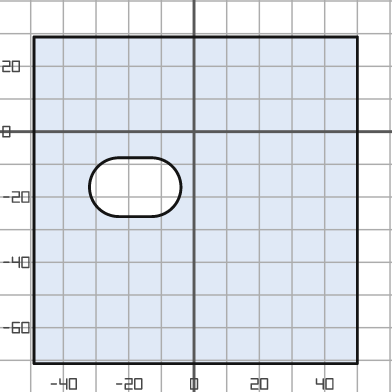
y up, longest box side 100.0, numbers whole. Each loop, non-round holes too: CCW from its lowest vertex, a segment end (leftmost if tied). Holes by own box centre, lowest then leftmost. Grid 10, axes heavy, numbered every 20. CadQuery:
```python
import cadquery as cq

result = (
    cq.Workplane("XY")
    .moveTo(-49.0, -71.0)
    .lineTo(50.0, -71.0)
    .lineTo(50.0, 29.0)
    .lineTo(-49.0, 29.0)
    .close()
    .moveTo(-23.0, -26.0)
    .lineTo(-13.0, -26.0)
    .threePointArc((-4.0, -17.0), (-13.0, -8.0))
    .lineTo(-23.0, -8.0)
    .threePointArc((-32.0, -17.0), (-23.0, -26.0))
    .close()
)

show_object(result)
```